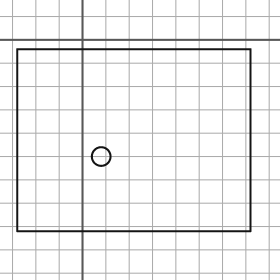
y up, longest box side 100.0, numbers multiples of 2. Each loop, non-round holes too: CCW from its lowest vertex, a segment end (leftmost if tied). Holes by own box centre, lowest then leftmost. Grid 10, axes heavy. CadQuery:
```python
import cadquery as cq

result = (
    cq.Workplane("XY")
    .moveTo(-28.0, -82.0)
    .lineTo(72.0, -82.0)
    .lineTo(72.0, -4.0)
    .lineTo(-28.0, -4.0)
    .close()
    .moveTo(8.0, -50.0)
    .circle(4.0)
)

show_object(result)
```